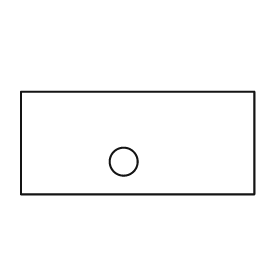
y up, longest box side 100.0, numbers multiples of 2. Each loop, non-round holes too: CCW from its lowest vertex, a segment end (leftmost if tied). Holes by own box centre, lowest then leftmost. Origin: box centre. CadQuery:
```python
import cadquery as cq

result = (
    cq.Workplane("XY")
    .moveTo(-50.0, -22.0)
    .lineTo(50.0, -22.0)
    .lineTo(50.0, 22.0)
    .lineTo(-50.0, 22.0)
    .close()
    .moveTo(-6.0, -8.0)
    .circle(6.0)
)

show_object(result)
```